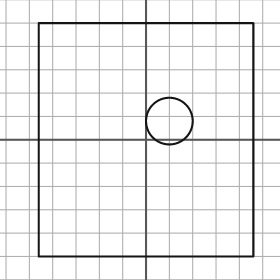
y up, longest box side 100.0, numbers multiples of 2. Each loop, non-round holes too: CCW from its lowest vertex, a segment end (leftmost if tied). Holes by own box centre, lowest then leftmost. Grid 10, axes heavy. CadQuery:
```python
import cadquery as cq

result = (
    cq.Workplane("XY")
    .moveTo(-46.0, -50.0)
    .lineTo(46.0, -50.0)
    .lineTo(46.0, 50.0)
    .lineTo(-46.0, 50.0)
    .close()
    .moveTo(10.0, 8.0)
    .circle(10.0)
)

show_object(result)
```